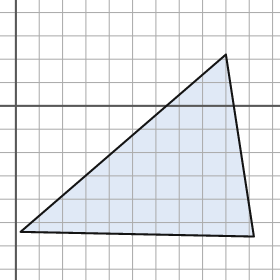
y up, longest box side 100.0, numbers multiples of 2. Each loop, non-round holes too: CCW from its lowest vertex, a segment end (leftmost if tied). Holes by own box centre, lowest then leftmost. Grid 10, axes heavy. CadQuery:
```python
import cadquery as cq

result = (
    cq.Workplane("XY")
    .moveTo(102.0, -56.0)
    .lineTo(90.0, 22.0)
    .lineTo(2.0, -54.0)
    .close()
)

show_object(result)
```